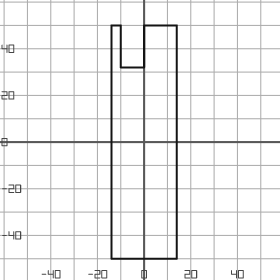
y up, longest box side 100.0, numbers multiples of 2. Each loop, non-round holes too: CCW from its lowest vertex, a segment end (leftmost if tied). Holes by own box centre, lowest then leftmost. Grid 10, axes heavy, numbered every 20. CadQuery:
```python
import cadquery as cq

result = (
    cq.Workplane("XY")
    .moveTo(-14.0, -50.0)
    .lineTo(14.0, -50.0)
    .lineTo(14.0, 50.0)
    .lineTo(0.0, 50.0)
    .lineTo(0.0, 32.0)
    .lineTo(-10.0, 32.0)
    .lineTo(-10.0, 50.0)
    .lineTo(-14.0, 50.0)
    .close()
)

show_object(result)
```